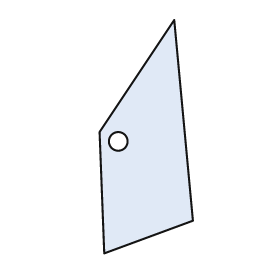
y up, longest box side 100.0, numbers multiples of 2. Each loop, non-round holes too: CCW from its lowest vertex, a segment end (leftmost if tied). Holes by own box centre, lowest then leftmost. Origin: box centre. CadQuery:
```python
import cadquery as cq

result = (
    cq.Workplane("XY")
    .moveTo(-18.0, -50.0)
    .lineTo(20.0, -36.0)
    .lineTo(12.0, 50.0)
    .lineTo(-20.0, 2.0)
    .close()
    .moveTo(-12.0, -2.0)
    .circle(4.0)
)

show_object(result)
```